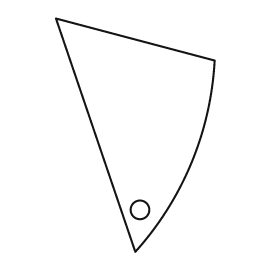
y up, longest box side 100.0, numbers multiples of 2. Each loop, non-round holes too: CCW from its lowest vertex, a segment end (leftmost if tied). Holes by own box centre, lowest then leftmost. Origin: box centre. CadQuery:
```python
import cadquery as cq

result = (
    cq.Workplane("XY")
    .moveTo(0.0, -50.0)
    .threePointArc((24.0, -12.0), (34.0, 32.0))
    .lineTo(-34.0, 50.0)
    .close()
    .moveTo(2.0, -32.0)
    .circle(4.0)
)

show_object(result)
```